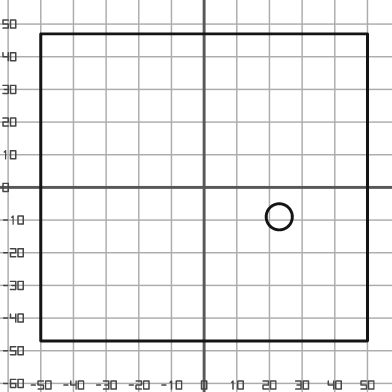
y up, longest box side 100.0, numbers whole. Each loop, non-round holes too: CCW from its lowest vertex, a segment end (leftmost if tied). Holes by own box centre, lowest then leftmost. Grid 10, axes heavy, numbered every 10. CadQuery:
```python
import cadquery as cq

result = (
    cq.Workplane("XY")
    .moveTo(-50.0, -47.0)
    .lineTo(50.0, -47.0)
    .lineTo(50.0, 47.0)
    .lineTo(-50.0, 47.0)
    .close()
    .moveTo(23.0, -9.0)
    .circle(4.0)
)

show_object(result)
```